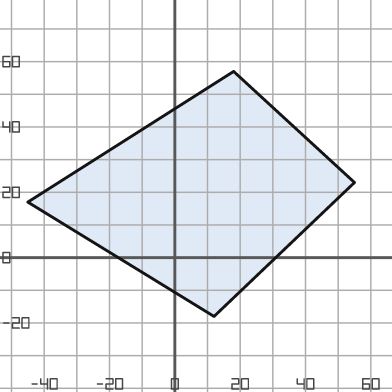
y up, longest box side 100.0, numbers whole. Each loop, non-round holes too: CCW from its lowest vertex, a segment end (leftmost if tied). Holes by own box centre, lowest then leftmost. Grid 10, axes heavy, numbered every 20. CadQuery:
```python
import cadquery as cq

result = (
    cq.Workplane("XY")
    .moveTo(12.0, -18.0)
    .lineTo(55.0, 23.0)
    .lineTo(18.0, 57.0)
    .lineTo(-45.0, 17.0)
    .close()
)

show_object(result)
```